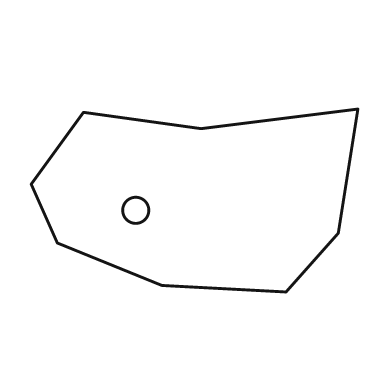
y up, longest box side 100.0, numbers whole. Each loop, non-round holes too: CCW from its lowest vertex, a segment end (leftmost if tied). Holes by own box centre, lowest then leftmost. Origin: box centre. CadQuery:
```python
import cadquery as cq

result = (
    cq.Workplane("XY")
    .moveTo(28.0, -28.0)
    .lineTo(44.0, -10.0)
    .lineTo(50.0, 28.0)
    .lineTo(2.0, 22.0)
    .lineTo(-34.0, 27.0)
    .lineTo(-50.0, 5.0)
    .lineTo(-42.0, -13.0)
    .lineTo(-10.0, -26.0)
    .close()
    .moveTo(-18.0, -3.0)
    .circle(4.0)
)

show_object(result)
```